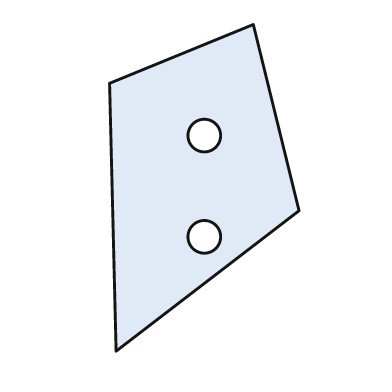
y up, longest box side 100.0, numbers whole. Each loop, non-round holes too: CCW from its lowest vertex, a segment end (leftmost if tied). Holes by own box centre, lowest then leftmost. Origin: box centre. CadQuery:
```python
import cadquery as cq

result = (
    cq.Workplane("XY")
    .moveTo(-27.0, -50.0)
    .lineTo(29.0, -7.0)
    .lineTo(15.0, 50.0)
    .lineTo(-29.0, 32.0)
    .close()
    .moveTo(0.0, -15.0)
    .circle(5.0)
    .moveTo(0.0, 16.0)
    .circle(5.0)
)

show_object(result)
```